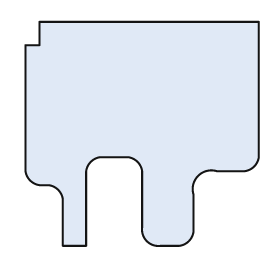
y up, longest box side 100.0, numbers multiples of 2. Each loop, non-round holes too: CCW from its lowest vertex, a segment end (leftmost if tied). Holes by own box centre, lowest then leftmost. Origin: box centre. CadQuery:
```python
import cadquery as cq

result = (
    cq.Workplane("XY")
    .moveTo(-34.0, -48.0)
    .lineTo(-24.0, -48.0)
    .lineTo(-24.0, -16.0)
    .threePointArc((-22.0, -12.0), (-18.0, -10.0))
    .lineTo(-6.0, -10.0)
    .threePointArc((-2.0, -12.0), (0.0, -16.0))
    .lineTo(0.0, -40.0)
    .threePointArc((2.0, -46.0), (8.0, -48.0))
    .lineTo(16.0, -48.0)
    .threePointArc((20.0, -46.0), (22.0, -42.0))
    .lineTo(22.0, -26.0)
    .threePointArc((24.0, -18.0), (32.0, -16.0))
    .lineTo(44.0, -16.0)
    .threePointArc((48.0, -14.0), (50.0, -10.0))
    .lineTo(50.0, 48.0)
    .lineTo(-44.0, 48.0)
    .lineTo(-44.0, 38.0)
    .lineTo(-50.0, 38.0)
    .lineTo(-50.0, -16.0)
    .threePointArc((-48.0, -20.0), (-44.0, -22.0))
    .lineTo(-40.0, -22.0)
    .threePointArc((-36.0, -24.0), (-34.0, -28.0))
    .close()
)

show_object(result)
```